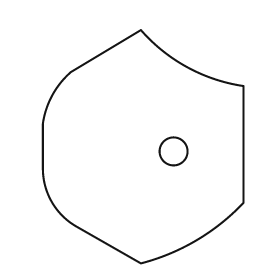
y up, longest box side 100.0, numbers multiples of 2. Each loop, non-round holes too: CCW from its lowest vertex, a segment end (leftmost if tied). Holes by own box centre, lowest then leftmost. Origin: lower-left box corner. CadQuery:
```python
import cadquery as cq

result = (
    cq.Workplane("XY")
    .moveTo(42.0, 0.0)
    .threePointArc((66.0, 10.0), (86.0, 26.0))
    .lineTo(86.0, 76.0)
    .threePointArc((62.0, 84.0), (42.0, 100.0))
    .lineTo(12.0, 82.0)
    .threePointArc((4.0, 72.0), (0.0, 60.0))
    .lineTo(0.0, 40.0)
    .threePointArc((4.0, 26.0), (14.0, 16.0))
    .close()
    .moveTo(56.0, 48.0)
    .circle(6.0)
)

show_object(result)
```